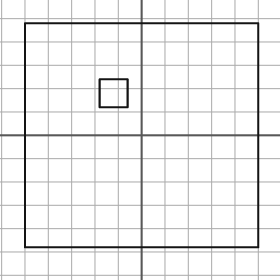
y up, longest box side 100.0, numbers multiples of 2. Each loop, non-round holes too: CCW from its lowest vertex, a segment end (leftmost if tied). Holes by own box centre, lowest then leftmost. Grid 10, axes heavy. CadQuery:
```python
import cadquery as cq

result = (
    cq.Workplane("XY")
    .moveTo(-50.0, -48.0)
    .lineTo(50.0, -48.0)
    .lineTo(50.0, 48.0)
    .lineTo(-50.0, 48.0)
    .close()
    .moveTo(-18.0, 12.0)
    .lineTo(-6.0, 12.0)
    .lineTo(-6.0, 24.0)
    .lineTo(-18.0, 24.0)
    .close()
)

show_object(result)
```